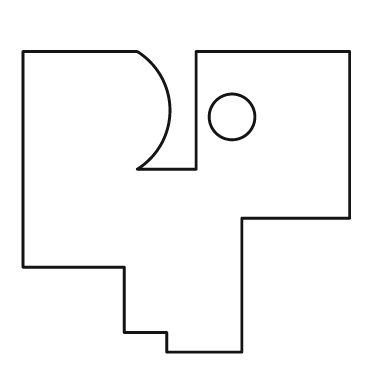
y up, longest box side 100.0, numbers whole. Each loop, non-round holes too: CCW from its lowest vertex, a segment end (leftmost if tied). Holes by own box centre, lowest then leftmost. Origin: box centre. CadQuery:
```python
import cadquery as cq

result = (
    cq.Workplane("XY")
    .moveTo(-6.0, -46.0)
    .lineTo(17.0, -46.0)
    .lineTo(17.0, -5.0)
    .lineTo(50.0, -5.0)
    .lineTo(50.0, 46.0)
    .lineTo(3.0, 46.0)
    .lineTo(3.0, 10.0)
    .lineTo(-15.0, 10.0)
    .threePointArc((-5.0, 28.0), (-15.0, 46.0))
    .lineTo(-50.0, 46.0)
    .lineTo(-50.0, -20.0)
    .lineTo(-19.0, -20.0)
    .lineTo(-19.0, -40.0)
    .lineTo(-6.0, -40.0)
    .close()
    .moveTo(14.0, 26.0)
    .circle(7.0)
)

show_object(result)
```